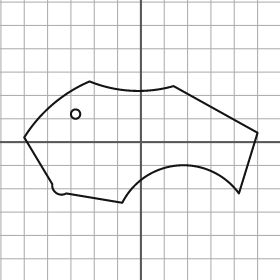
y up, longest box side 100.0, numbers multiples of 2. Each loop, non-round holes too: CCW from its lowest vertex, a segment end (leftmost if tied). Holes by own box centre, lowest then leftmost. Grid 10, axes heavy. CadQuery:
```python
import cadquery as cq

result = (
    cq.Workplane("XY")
    .moveTo(-8.0, -26.0)
    .threePointArc((16.0, -10.0), (42.0, -22.0))
    .lineTo(50.0, 4.0)
    .lineTo(14.0, 24.0)
    .threePointArc((-4.0, 22.0), (-22.0, 26.0))
    .threePointArc((-38.0, 16.0), (-50.0, 2.0))
    .lineTo(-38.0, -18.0)
    .threePointArc((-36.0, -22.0), (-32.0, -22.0))
    .close()
    .moveTo(-28.0, 12.0)
    .circle(2.0)
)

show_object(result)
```